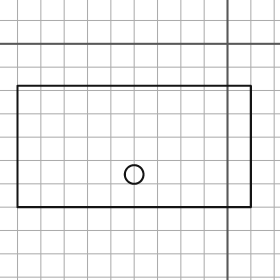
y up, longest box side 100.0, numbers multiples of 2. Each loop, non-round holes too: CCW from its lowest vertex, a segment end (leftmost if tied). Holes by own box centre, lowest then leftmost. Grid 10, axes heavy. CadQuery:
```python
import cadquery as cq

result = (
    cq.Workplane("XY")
    .moveTo(-90.0, -70.0)
    .lineTo(10.0, -70.0)
    .lineTo(10.0, -18.0)
    .lineTo(-90.0, -18.0)
    .close()
    .moveTo(-40.0, -56.0)
    .circle(4.0)
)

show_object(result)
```